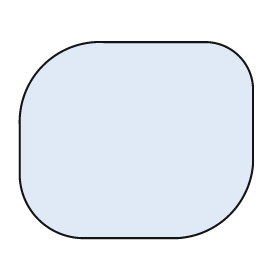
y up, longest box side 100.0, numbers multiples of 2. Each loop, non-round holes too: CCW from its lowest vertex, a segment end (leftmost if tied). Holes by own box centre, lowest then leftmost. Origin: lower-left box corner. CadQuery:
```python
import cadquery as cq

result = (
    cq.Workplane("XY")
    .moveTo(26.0, 0.0)
    .lineTo(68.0, 0.0)
    .threePointArc((90.0, 10.0), (100.0, 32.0))
    .lineTo(100.0, 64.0)
    .threePointArc((94.0, 78.0), (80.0, 84.0))
    .lineTo(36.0, 84.0)
    .threePointArc((10.0, 74.0), (0.0, 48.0))
    .lineTo(0.0, 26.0)
    .threePointArc((8.0, 8.0), (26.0, 0.0))
    .close()
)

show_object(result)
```